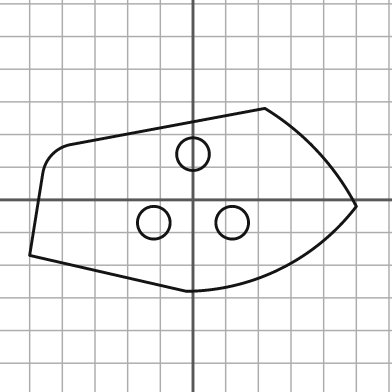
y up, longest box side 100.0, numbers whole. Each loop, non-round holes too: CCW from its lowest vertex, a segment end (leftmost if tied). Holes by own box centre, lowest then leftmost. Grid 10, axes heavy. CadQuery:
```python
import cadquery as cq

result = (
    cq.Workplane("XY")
    .moveTo(-2.0, -28.0)
    .threePointArc((27.0, -21.0), (50.0, -2.0))
    .threePointArc((38.0, 15.0), (22.0, 28.0))
    .lineTo(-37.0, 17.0)
    .threePointArc((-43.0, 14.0), (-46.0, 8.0))
    .lineTo(-50.0, -17.0)
    .close()
    .moveTo(-12.0, -7.0)
    .circle(5.0)
    .moveTo(12.0, -7.0)
    .circle(5.0)
    .moveTo(0.0, 14.0)
    .circle(5.0)
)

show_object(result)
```